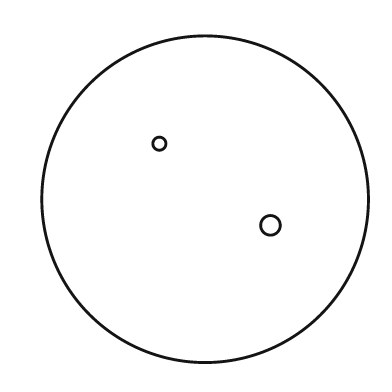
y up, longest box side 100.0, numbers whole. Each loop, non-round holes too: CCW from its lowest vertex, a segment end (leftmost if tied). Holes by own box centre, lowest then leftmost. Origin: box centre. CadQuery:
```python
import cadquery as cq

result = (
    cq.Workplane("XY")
    .moveTo(0.0, 0.0)
    .circle(50.0)
    .moveTo(20.0, -8.0)
    .circle(3.0)
    .moveTo(-14.0, 17.0)
    .circle(2.0)
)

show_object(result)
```